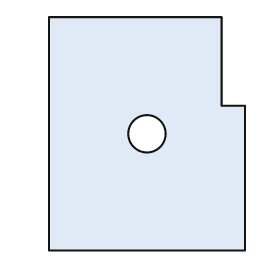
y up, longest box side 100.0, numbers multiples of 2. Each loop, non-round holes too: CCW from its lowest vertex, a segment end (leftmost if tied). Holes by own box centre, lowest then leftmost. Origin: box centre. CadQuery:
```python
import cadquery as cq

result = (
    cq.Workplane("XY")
    .moveTo(-42.0, -50.0)
    .lineTo(42.0, -50.0)
    .lineTo(42.0, 12.0)
    .lineTo(32.0, 12.0)
    .lineTo(32.0, 50.0)
    .lineTo(-42.0, 50.0)
    .close()
    .moveTo(0.0, 0.0)
    .circle(8.0)
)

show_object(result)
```